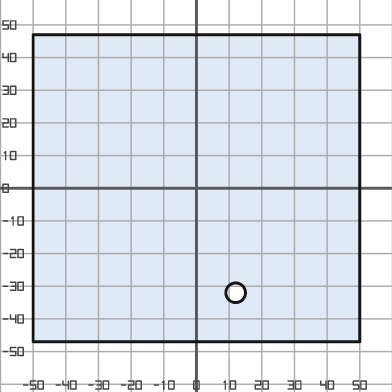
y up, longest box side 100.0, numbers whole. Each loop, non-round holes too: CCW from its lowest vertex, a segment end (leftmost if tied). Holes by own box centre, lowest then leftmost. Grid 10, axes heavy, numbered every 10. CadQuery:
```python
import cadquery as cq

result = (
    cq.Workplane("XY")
    .moveTo(-50.0, -47.0)
    .lineTo(50.0, -47.0)
    .lineTo(50.0, 47.0)
    .lineTo(-50.0, 47.0)
    .close()
    .moveTo(12.0, -32.0)
    .circle(3.0)
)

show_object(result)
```